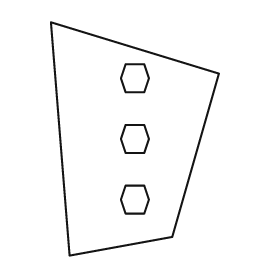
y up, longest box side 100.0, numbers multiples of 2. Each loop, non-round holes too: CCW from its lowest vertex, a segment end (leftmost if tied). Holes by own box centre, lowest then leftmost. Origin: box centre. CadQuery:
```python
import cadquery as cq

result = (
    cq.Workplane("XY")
    .moveTo(-28.0, -50.0)
    .lineTo(16.0, -42.0)
    .lineTo(36.0, 28.0)
    .lineTo(-36.0, 50.0)
    .close()
    .moveTo(-4.0, -32.0)
    .lineTo(4.0, -32.0)
    .lineTo(6.0, -26.0)
    .lineTo(4.0, -20.0)
    .lineTo(-4.0, -20.0)
    .lineTo(-6.0, -26.0)
    .close()
    .moveTo(-4.0, -6.0)
    .lineTo(4.0, -6.0)
    .lineTo(6.0, 0.0)
    .lineTo(4.0, 6.0)
    .lineTo(-4.0, 6.0)
    .lineTo(-6.0, 0.0)
    .close()
    .moveTo(-4.0, 20.0)
    .lineTo(4.0, 20.0)
    .lineTo(6.0, 26.0)
    .lineTo(4.0, 32.0)
    .lineTo(-4.0, 32.0)
    .lineTo(-6.0, 26.0)
    .close()
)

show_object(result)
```